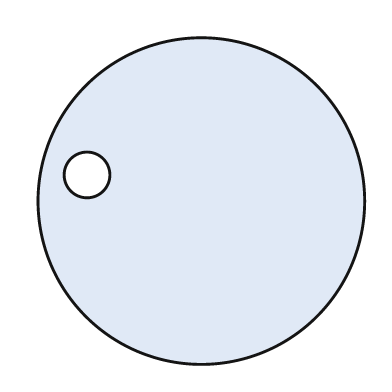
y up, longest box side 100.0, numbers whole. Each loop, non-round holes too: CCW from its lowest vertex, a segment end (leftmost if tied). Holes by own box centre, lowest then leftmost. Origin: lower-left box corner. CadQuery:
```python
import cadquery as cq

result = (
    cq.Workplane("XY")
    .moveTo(50.0, 50.0)
    .circle(50.0)
    .moveTo(15.0, 58.0)
    .circle(7.0)
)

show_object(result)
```